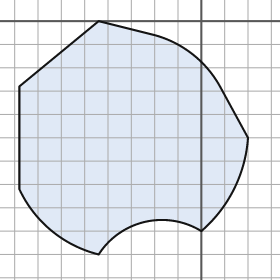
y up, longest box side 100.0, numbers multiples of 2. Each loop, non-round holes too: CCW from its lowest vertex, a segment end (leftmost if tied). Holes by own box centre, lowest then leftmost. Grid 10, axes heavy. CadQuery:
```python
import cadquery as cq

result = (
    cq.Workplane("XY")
    .moveTo(-44.0, -100.0)
    .threePointArc((-24.0, -86.0), (0.0, -90.0))
    .threePointArc((14.0, -72.0), (20.0, -50.0))
    .lineTo(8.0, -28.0)
    .threePointArc((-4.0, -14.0), (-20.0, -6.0))
    .lineTo(-44.0, 0.0)
    .lineTo(-78.0, -28.0)
    .lineTo(-78.0, -72.0)
    .threePointArc((-64.0, -90.0), (-44.0, -100.0))
    .close()
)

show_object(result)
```